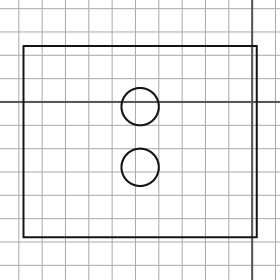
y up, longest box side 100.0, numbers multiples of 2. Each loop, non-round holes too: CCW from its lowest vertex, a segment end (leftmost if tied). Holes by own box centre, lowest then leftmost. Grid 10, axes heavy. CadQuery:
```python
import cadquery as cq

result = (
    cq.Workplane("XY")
    .moveTo(-98.0, -58.0)
    .lineTo(2.0, -58.0)
    .lineTo(2.0, 24.0)
    .lineTo(-98.0, 24.0)
    .close()
    .moveTo(-48.0, -28.0)
    .circle(8.0)
    .moveTo(-48.0, -2.0)
    .circle(8.0)
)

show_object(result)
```